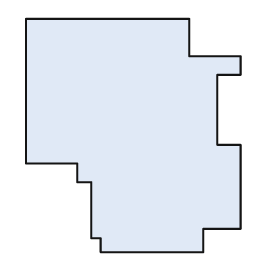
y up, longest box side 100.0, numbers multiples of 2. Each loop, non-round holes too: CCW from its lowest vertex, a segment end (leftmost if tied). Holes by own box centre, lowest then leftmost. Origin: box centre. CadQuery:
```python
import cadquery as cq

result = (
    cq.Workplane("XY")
    .moveTo(-14.0, -50.0)
    .lineTo(30.0, -50.0)
    .lineTo(30.0, -40.0)
    .lineTo(46.0, -40.0)
    .lineTo(46.0, -4.0)
    .lineTo(36.0, -4.0)
    .lineTo(36.0, 26.0)
    .lineTo(46.0, 26.0)
    .lineTo(46.0, 34.0)
    .lineTo(24.0, 34.0)
    .lineTo(24.0, 50.0)
    .lineTo(-46.0, 50.0)
    .lineTo(-46.0, -12.0)
    .lineTo(-24.0, -12.0)
    .lineTo(-24.0, -20.0)
    .lineTo(-18.0, -20.0)
    .lineTo(-18.0, -44.0)
    .lineTo(-14.0, -44.0)
    .close()
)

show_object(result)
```